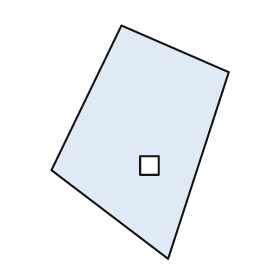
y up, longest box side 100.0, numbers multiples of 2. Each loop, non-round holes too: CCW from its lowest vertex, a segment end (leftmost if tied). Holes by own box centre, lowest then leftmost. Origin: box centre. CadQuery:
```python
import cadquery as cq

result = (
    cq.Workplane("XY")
    .moveTo(12.0, -50.0)
    .lineTo(38.0, 30.0)
    .lineTo(-8.0, 50.0)
    .lineTo(-38.0, -12.0)
    .close()
    .moveTo(0.0, -14.0)
    .lineTo(8.0, -14.0)
    .lineTo(8.0, -6.0)
    .lineTo(0.0, -6.0)
    .close()
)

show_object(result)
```